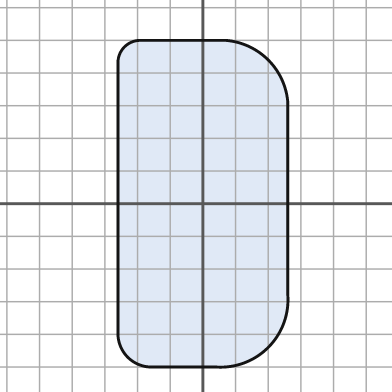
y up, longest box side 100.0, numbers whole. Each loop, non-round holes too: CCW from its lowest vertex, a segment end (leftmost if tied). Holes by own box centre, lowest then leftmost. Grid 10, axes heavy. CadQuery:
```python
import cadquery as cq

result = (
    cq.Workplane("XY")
    .moveTo(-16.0, -50.0)
    .lineTo(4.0, -50.0)
    .threePointArc((20.0, -44.0), (26.0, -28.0))
    .lineTo(26.0, 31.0)
    .threePointArc((20.0, 44.0), (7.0, 50.0))
    .lineTo(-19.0, 50.0)
    .threePointArc((-24.0, 48.0), (-26.0, 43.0))
    .lineTo(-26.0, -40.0)
    .threePointArc((-23.0, -47.0), (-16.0, -50.0))
    .close()
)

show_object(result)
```